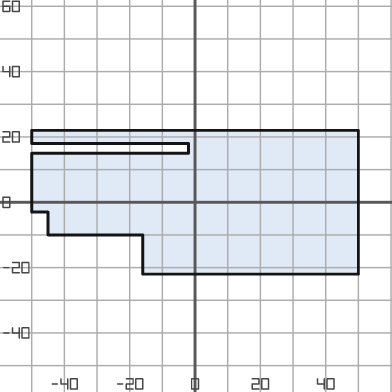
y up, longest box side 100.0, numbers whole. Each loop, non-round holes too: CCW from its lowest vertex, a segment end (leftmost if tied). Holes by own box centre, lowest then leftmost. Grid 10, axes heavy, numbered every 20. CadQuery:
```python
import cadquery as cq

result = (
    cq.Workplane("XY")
    .moveTo(-16.0, -22.0)
    .lineTo(50.0, -22.0)
    .lineTo(50.0, 22.0)
    .lineTo(-50.0, 22.0)
    .lineTo(-50.0, 18.0)
    .lineTo(-2.0, 18.0)
    .lineTo(-2.0, 15.0)
    .lineTo(-50.0, 15.0)
    .lineTo(-50.0, -3.0)
    .lineTo(-45.0, -3.0)
    .lineTo(-45.0, -10.0)
    .lineTo(-16.0, -10.0)
    .close()
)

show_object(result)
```